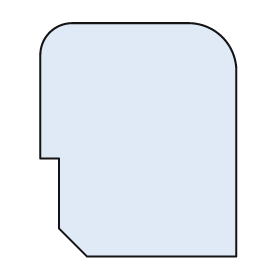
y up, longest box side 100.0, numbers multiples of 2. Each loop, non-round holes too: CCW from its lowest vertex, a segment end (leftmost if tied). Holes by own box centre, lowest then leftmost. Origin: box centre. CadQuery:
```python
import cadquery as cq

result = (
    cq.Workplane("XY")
    .moveTo(-22.0, -50.0)
    .lineTo(42.0, -50.0)
    .lineTo(42.0, 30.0)
    .threePointArc((36.0, 44.0), (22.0, 50.0))
    .lineTo(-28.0, 50.0)
    .threePointArc((-38.0, 46.0), (-42.0, 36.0))
    .lineTo(-42.0, -8.0)
    .lineTo(-34.0, -8.0)
    .lineTo(-34.0, -38.0)
    .close()
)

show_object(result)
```